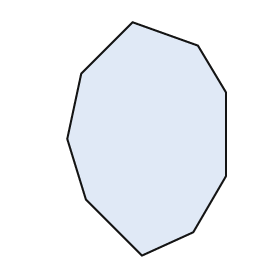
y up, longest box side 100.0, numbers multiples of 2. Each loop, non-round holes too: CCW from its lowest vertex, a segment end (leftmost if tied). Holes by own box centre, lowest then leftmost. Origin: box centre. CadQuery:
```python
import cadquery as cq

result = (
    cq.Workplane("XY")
    .moveTo(-2.0, -50.0)
    .lineTo(20.0, -40.0)
    .lineTo(34.0, -16.0)
    .lineTo(34.0, 20.0)
    .lineTo(22.0, 40.0)
    .lineTo(-6.0, 50.0)
    .lineTo(-28.0, 28.0)
    .lineTo(-34.0, 0.0)
    .lineTo(-26.0, -26.0)
    .close()
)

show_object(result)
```